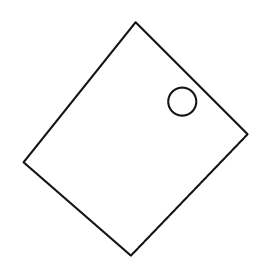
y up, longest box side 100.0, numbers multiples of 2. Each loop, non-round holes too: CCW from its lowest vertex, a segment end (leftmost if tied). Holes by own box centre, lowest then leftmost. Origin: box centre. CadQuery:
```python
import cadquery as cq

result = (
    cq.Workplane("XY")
    .moveTo(-2.0, -50.0)
    .lineTo(48.0, 2.0)
    .lineTo(0.0, 50.0)
    .lineTo(-48.0, -10.0)
    .close()
    .moveTo(20.0, 16.0)
    .circle(6.0)
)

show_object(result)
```